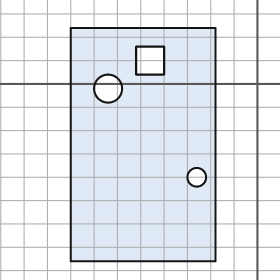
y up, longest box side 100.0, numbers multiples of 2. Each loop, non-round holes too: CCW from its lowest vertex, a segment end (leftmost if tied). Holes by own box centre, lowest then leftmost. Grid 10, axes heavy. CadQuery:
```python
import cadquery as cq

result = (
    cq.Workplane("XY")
    .moveTo(-80.0, -76.0)
    .lineTo(-18.0, -76.0)
    .lineTo(-18.0, 24.0)
    .lineTo(-80.0, 24.0)
    .close()
    .moveTo(-26.0, -40.0)
    .circle(4.0)
    .moveTo(-64.0, -2.0)
    .circle(6.0)
    .moveTo(-52.0, 4.0)
    .lineTo(-40.0, 4.0)
    .lineTo(-40.0, 16.0)
    .lineTo(-52.0, 16.0)
    .close()
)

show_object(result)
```